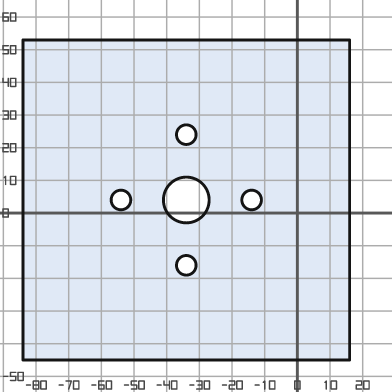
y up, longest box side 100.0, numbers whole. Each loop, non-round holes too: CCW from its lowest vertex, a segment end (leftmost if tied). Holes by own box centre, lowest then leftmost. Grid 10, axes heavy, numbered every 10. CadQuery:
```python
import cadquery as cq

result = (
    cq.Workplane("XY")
    .moveTo(-84.0, -45.0)
    .lineTo(16.0, -45.0)
    .lineTo(16.0, 53.0)
    .lineTo(-84.0, 53.0)
    .close()
    .moveTo(-34.0, -16.0)
    .circle(3.0)
    .moveTo(-54.0, 4.0)
    .circle(3.0)
    .moveTo(-34.0, 4.0)
    .circle(7.0)
    .moveTo(-14.0, 4.0)
    .circle(3.0)
    .moveTo(-34.0, 24.0)
    .circle(3.0)
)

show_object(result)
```